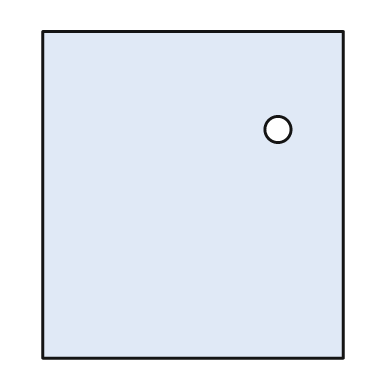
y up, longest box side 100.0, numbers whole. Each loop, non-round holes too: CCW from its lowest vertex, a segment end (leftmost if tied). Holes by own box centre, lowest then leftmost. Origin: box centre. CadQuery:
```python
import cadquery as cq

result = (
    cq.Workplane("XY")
    .moveTo(-46.0, -50.0)
    .lineTo(46.0, -50.0)
    .lineTo(46.0, 50.0)
    .lineTo(-46.0, 50.0)
    .close()
    .moveTo(26.0, 20.0)
    .circle(4.0)
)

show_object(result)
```